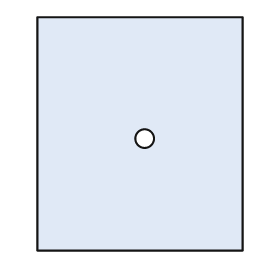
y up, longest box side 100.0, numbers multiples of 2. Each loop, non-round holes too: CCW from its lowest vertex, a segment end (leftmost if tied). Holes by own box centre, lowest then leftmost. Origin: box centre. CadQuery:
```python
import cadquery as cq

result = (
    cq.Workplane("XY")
    .moveTo(-44.0, -50.0)
    .lineTo(44.0, -50.0)
    .lineTo(44.0, 50.0)
    .lineTo(-44.0, 50.0)
    .close()
    .moveTo(2.0, -2.0)
    .circle(4.0)
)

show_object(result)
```